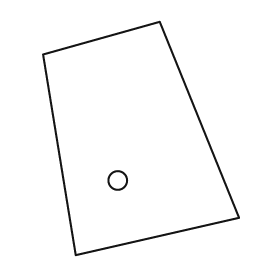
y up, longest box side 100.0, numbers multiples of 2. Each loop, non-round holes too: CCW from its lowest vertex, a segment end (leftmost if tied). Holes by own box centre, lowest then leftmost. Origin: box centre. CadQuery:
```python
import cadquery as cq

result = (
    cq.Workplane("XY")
    .moveTo(-28.0, -50.0)
    .lineTo(42.0, -34.0)
    .lineTo(8.0, 50.0)
    .lineTo(-42.0, 36.0)
    .close()
    .moveTo(-10.0, -18.0)
    .circle(4.0)
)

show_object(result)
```